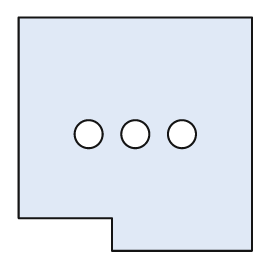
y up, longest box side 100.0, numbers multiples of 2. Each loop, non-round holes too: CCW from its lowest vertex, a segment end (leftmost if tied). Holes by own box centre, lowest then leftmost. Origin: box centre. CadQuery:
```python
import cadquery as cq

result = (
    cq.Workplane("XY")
    .moveTo(-10.0, -50.0)
    .lineTo(50.0, -50.0)
    .lineTo(50.0, 50.0)
    .lineTo(-50.0, 50.0)
    .lineTo(-50.0, -36.0)
    .lineTo(-10.0, -36.0)
    .close()
    .moveTo(-20.0, 0.0)
    .circle(6.0)
    .moveTo(0.0, 0.0)
    .circle(6.0)
    .moveTo(20.0, 0.0)
    .circle(6.0)
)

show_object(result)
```